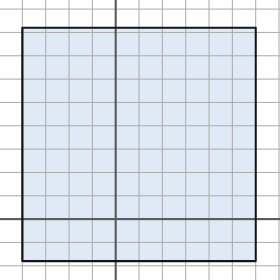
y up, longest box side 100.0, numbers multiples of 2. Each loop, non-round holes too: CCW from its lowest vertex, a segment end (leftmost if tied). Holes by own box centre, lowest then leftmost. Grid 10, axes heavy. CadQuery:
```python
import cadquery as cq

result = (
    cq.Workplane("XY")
    .moveTo(-40.0, -18.0)
    .lineTo(60.0, -18.0)
    .lineTo(60.0, 82.0)
    .lineTo(-40.0, 82.0)
    .close()
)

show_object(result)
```